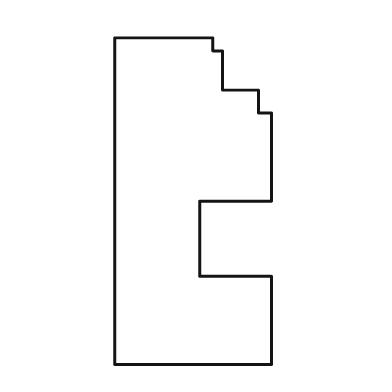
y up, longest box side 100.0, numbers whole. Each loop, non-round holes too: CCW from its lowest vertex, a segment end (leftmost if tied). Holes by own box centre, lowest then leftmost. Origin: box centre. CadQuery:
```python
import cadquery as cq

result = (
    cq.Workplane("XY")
    .moveTo(-24.0, -50.0)
    .lineTo(24.0, -50.0)
    .lineTo(24.0, -23.0)
    .lineTo(2.0, -23.0)
    .lineTo(2.0, 0.0)
    .lineTo(24.0, 0.0)
    .lineTo(24.0, 27.0)
    .lineTo(20.0, 27.0)
    .lineTo(20.0, 34.0)
    .lineTo(9.0, 34.0)
    .lineTo(9.0, 46.0)
    .lineTo(6.0, 46.0)
    .lineTo(6.0, 50.0)
    .lineTo(-24.0, 50.0)
    .close()
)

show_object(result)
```